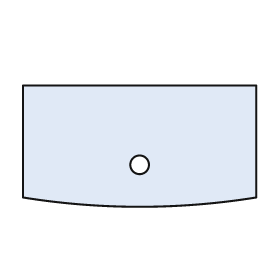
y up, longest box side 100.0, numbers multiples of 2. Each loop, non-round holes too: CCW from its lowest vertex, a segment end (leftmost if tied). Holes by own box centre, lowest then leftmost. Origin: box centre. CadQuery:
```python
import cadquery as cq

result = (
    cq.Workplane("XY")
    .moveTo(-50.0, -22.0)
    .threePointArc((0.0, -26.0), (50.0, -22.0))
    .lineTo(50.0, 26.0)
    .lineTo(-50.0, 26.0)
    .close()
    .moveTo(0.0, -8.0)
    .circle(4.0)
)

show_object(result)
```